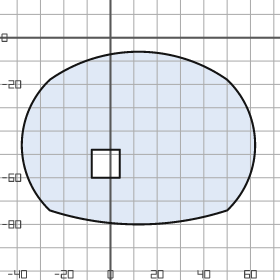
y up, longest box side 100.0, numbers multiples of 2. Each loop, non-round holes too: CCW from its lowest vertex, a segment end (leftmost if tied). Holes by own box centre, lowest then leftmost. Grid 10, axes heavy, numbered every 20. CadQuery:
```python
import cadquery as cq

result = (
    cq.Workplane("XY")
    .moveTo(-26.0, -74.0)
    .threePointArc((12.0, -80.0), (50.0, -74.0))
    .threePointArc((62.0, -46.0), (50.0, -18.0))
    .threePointArc((12.0, -6.0), (-26.0, -18.0))
    .threePointArc((-38.0, -46.0), (-26.0, -74.0))
    .close()
    .moveTo(-8.0, -60.0)
    .lineTo(4.0, -60.0)
    .lineTo(4.0, -48.0)
    .lineTo(-8.0, -48.0)
    .close()
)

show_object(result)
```